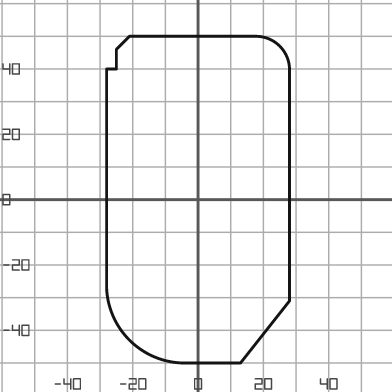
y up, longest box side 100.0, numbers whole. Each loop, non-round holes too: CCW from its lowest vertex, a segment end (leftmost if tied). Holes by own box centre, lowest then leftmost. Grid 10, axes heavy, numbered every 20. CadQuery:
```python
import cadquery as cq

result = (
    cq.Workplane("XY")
    .moveTo(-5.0, -50.0)
    .lineTo(13.0, -50.0)
    .lineTo(28.0, -31.0)
    .lineTo(28.0, 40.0)
    .threePointArc((25.0, 47.0), (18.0, 50.0))
    .lineTo(-21.0, 50.0)
    .lineTo(-25.0, 46.0)
    .lineTo(-25.0, 40.0)
    .lineTo(-28.0, 40.0)
    .lineTo(-28.0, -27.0)
    .threePointArc((-21.0, -43.0), (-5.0, -50.0))
    .close()
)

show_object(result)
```